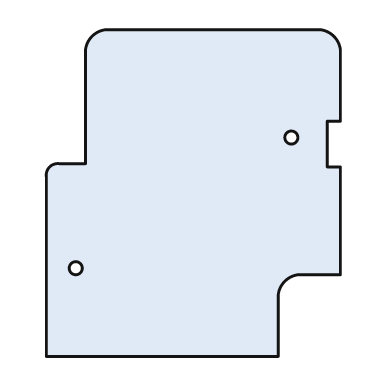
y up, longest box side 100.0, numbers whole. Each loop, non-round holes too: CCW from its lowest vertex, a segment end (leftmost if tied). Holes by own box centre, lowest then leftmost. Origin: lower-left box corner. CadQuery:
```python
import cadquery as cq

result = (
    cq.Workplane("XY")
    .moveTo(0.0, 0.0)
    .lineTo(71.0, 0.0)
    .lineTo(71.0, 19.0)
    .threePointArc((73.0, 23.0), (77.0, 25.0))
    .lineTo(90.0, 25.0)
    .lineTo(90.0, 58.0)
    .lineTo(86.0, 58.0)
    .lineTo(86.0, 72.0)
    .lineTo(90.0, 72.0)
    .lineTo(90.0, 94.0)
    .threePointArc((88.0, 98.0), (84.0, 100.0))
    .lineTo(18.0, 100.0)
    .threePointArc((14.0, 98.0), (12.0, 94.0))
    .lineTo(12.0, 59.0)
    .lineTo(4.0, 59.0)
    .threePointArc((1.0, 58.0), (0.0, 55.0))
    .close()
    .moveTo(9.0, 27.0)
    .circle(2.0)
    .moveTo(75.0, 67.0)
    .circle(2.0)
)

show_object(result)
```